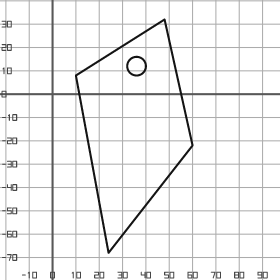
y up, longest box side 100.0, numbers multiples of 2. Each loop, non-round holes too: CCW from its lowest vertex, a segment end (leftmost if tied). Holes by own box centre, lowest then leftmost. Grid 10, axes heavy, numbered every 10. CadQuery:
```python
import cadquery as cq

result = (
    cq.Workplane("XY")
    .moveTo(24.0, -68.0)
    .lineTo(60.0, -22.0)
    .lineTo(48.0, 32.0)
    .lineTo(10.0, 8.0)
    .close()
    .moveTo(36.0, 12.0)
    .circle(4.0)
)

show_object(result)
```